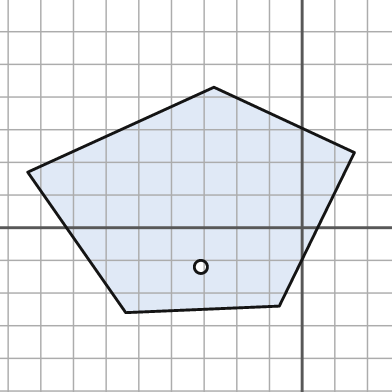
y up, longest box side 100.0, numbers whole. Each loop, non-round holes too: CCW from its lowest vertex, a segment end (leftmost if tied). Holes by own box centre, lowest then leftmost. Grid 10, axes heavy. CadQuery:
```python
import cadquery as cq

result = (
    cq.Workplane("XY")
    .moveTo(-54.0, -26.0)
    .lineTo(-7.0, -24.0)
    .lineTo(16.0, 23.0)
    .lineTo(-27.0, 43.0)
    .lineTo(-84.0, 17.0)
    .close()
    .moveTo(-31.0, -12.0)
    .circle(2.0)
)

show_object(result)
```